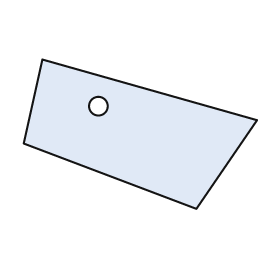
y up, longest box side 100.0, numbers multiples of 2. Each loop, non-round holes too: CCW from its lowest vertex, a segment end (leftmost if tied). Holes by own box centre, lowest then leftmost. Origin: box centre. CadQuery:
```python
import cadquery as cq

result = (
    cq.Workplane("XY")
    .moveTo(24.0, -32.0)
    .lineTo(50.0, 6.0)
    .lineTo(-42.0, 32.0)
    .lineTo(-50.0, -4.0)
    .close()
    .moveTo(-18.0, 12.0)
    .circle(4.0)
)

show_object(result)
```